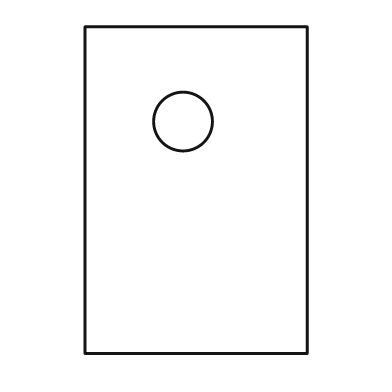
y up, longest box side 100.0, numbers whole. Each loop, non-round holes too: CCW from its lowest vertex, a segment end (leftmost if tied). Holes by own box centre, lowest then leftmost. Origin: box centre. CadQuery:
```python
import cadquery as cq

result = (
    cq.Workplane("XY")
    .moveTo(-34.0, -50.0)
    .lineTo(34.0, -50.0)
    .lineTo(34.0, 50.0)
    .lineTo(-34.0, 50.0)
    .close()
    .moveTo(-4.0, 21.0)
    .circle(9.0)
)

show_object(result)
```